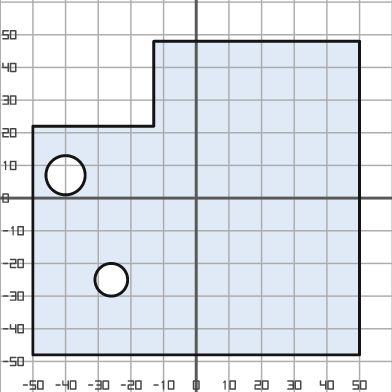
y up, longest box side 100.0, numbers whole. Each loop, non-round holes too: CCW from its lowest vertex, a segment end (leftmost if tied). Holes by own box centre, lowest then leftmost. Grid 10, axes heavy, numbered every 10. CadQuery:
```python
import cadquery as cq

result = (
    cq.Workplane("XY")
    .moveTo(-50.0, -48.0)
    .lineTo(50.0, -48.0)
    .lineTo(50.0, 48.0)
    .lineTo(-13.0, 48.0)
    .lineTo(-13.0, 22.0)
    .lineTo(-50.0, 22.0)
    .close()
    .moveTo(-26.0, -25.0)
    .circle(5.0)
    .moveTo(-40.0, 7.0)
    .circle(6.0)
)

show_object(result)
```